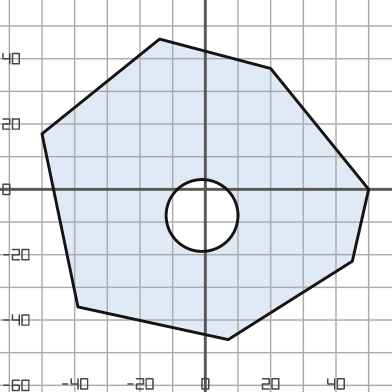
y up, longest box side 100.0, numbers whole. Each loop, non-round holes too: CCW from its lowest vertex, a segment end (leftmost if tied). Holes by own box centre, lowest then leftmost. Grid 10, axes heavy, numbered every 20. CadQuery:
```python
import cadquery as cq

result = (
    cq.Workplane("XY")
    .moveTo(7.0, -46.0)
    .lineTo(45.0, -22.0)
    .lineTo(50.0, 0.0)
    .lineTo(20.0, 37.0)
    .lineTo(-14.0, 46.0)
    .lineTo(-50.0, 17.0)
    .lineTo(-39.0, -36.0)
    .close()
    .moveTo(-1.0, -8.0)
    .circle(11.0)
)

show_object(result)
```